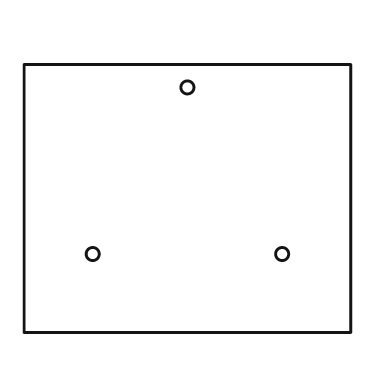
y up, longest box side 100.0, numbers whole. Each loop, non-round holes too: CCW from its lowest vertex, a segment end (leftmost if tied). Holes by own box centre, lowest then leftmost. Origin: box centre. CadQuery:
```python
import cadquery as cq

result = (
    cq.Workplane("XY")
    .moveTo(-50.0, -41.0)
    .lineTo(50.0, -41.0)
    .lineTo(50.0, 41.0)
    .lineTo(-50.0, 41.0)
    .close()
    .moveTo(-29.0, -17.0)
    .circle(2.0)
    .moveTo(29.0, -17.0)
    .circle(2.0)
    .moveTo(0.0, 34.0)
    .circle(2.0)
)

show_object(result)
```